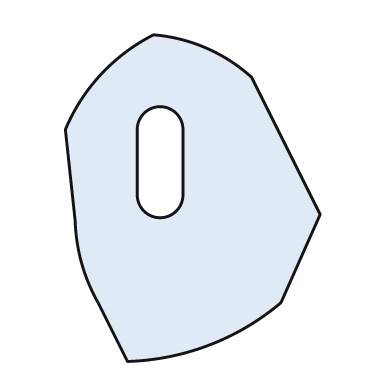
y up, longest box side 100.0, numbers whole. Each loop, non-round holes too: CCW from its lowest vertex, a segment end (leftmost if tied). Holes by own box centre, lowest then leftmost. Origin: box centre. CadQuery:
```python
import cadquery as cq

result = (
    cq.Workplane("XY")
    .moveTo(-20.0, -50.0)
    .threePointArc((5.0, -45.0), (27.0, -32.0))
    .lineTo(39.0, -5.0)
    .lineTo(18.0, 37.0)
    .threePointArc((4.0, 46.0), (-12.0, 50.0))
    .threePointArc((-28.0, 38.0), (-39.0, 21.0))
    .lineTo(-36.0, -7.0)
    .threePointArc((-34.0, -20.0), (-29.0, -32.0))
    .close()
    .moveTo(-17.0, 1.0)
    .threePointArc((-10.0, -6.0), (-3.0, 1.0))
    .lineTo(-3.0, 21.0)
    .threePointArc((-10.0, 28.0), (-17.0, 21.0))
    .close()
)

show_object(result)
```